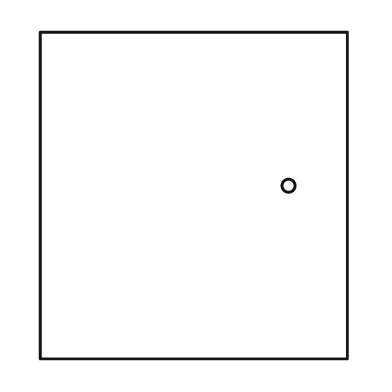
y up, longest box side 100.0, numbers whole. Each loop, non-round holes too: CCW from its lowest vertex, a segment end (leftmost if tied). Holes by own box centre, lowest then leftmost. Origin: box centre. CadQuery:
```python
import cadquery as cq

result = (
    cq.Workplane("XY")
    .moveTo(-47.0, -50.0)
    .lineTo(47.0, -50.0)
    .lineTo(47.0, 50.0)
    .lineTo(-47.0, 50.0)
    .close()
    .moveTo(29.0, 3.0)
    .circle(2.0)
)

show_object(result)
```